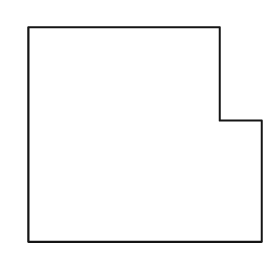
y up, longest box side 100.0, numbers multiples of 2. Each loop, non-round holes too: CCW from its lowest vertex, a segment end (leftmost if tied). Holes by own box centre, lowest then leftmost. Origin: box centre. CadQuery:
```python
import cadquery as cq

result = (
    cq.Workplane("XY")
    .moveTo(-50.0, -46.0)
    .lineTo(50.0, -46.0)
    .lineTo(50.0, 6.0)
    .lineTo(32.0, 6.0)
    .lineTo(32.0, 46.0)
    .lineTo(-50.0, 46.0)
    .close()
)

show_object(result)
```